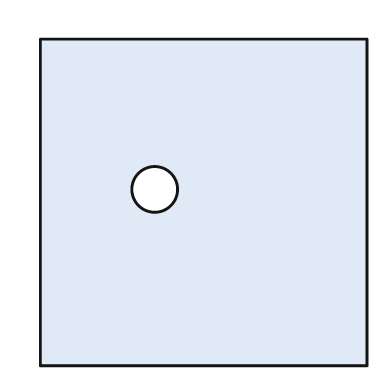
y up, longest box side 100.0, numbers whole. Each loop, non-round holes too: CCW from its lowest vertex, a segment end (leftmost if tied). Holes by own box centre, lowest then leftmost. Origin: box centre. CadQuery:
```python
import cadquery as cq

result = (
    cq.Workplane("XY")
    .moveTo(-50.0, -50.0)
    .lineTo(50.0, -50.0)
    .lineTo(50.0, 50.0)
    .lineTo(-50.0, 50.0)
    .close()
    .moveTo(-15.0, 4.0)
    .circle(7.0)
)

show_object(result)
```